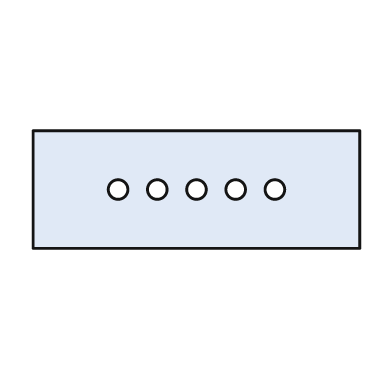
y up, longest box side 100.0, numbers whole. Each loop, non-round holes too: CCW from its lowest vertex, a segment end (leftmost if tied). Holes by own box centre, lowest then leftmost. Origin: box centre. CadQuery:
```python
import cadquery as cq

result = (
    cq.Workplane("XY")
    .moveTo(-50.0, -18.0)
    .lineTo(50.0, -18.0)
    .lineTo(50.0, 18.0)
    .lineTo(-50.0, 18.0)
    .close()
    .moveTo(-24.0, 0.0)
    .circle(3.0)
    .moveTo(-12.0, 0.0)
    .circle(3.0)
    .moveTo(0.0, 0.0)
    .circle(3.0)
    .moveTo(12.0, 0.0)
    .circle(3.0)
    .moveTo(24.0, 0.0)
    .circle(3.0)
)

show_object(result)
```